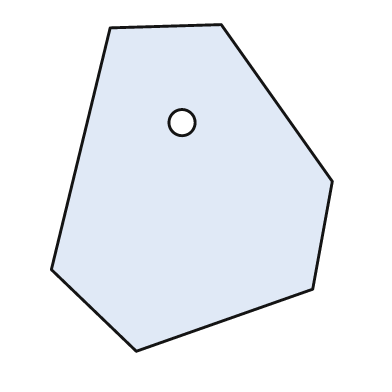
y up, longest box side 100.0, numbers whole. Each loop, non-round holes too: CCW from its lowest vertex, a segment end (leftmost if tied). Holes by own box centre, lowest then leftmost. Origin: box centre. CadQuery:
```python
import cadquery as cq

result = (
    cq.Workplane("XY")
    .moveTo(-17.0, -50.0)
    .lineTo(37.0, -31.0)
    .lineTo(43.0, 2.0)
    .lineTo(9.0, 50.0)
    .lineTo(-25.0, 49.0)
    .lineTo(-43.0, -25.0)
    .close()
    .moveTo(-3.0, 20.0)
    .circle(4.0)
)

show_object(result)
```